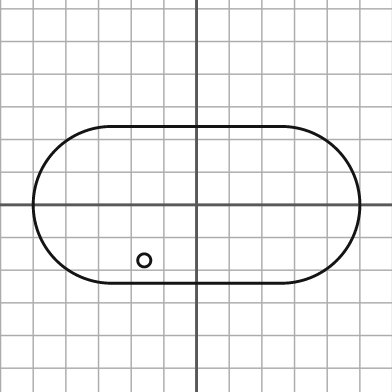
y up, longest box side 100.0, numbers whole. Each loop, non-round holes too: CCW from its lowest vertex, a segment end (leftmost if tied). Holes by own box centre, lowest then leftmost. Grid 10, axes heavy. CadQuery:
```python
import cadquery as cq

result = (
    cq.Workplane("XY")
    .moveTo(-26.0, -24.0)
    .lineTo(26.0, -24.0)
    .threePointArc((50.0, 0.0), (26.0, 24.0))
    .lineTo(-26.0, 24.0)
    .threePointArc((-50.0, 0.0), (-26.0, -24.0))
    .close()
    .moveTo(-16.0, -17.0)
    .circle(2.0)
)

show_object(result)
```